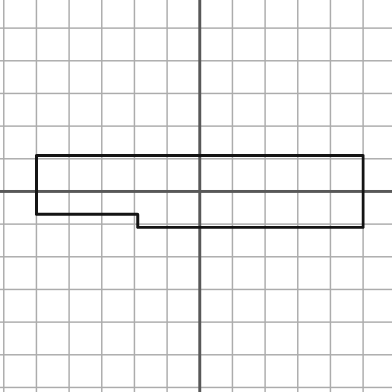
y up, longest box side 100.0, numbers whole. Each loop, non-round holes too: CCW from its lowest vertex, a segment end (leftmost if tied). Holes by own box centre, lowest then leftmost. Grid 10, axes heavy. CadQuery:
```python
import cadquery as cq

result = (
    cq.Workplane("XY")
    .moveTo(-19.0, -11.0)
    .lineTo(50.0, -11.0)
    .lineTo(50.0, 11.0)
    .lineTo(-50.0, 11.0)
    .lineTo(-50.0, -7.0)
    .lineTo(-19.0, -7.0)
    .close()
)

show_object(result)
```